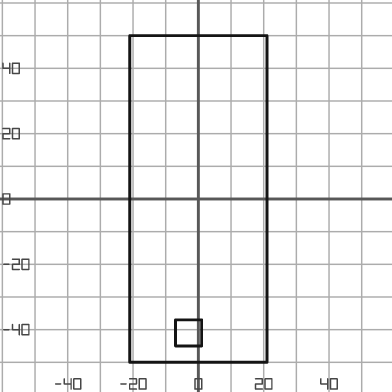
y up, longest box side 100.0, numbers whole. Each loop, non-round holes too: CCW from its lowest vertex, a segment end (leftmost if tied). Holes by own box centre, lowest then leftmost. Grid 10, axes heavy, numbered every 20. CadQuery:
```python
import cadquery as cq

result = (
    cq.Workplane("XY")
    .moveTo(-21.0, -50.0)
    .lineTo(21.0, -50.0)
    .lineTo(21.0, 50.0)
    .lineTo(-21.0, 50.0)
    .close()
    .moveTo(-7.0, -45.0)
    .lineTo(1.0, -45.0)
    .lineTo(1.0, -37.0)
    .lineTo(-7.0, -37.0)
    .close()
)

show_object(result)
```